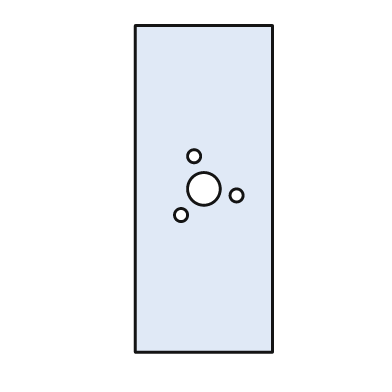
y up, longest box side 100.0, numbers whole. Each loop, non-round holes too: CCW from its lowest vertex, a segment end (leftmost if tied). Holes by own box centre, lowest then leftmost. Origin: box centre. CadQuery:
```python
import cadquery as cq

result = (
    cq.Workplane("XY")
    .moveTo(-21.0, -50.0)
    .lineTo(21.0, -50.0)
    .lineTo(21.0, 50.0)
    .lineTo(-21.0, 50.0)
    .close()
    .moveTo(-7.0, -8.0)
    .circle(2.0)
    .moveTo(10.0, -2.0)
    .circle(2.0)
    .moveTo(0.0, 0.0)
    .circle(5.0)
    .moveTo(-3.0, 10.0)
    .circle(2.0)
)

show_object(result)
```